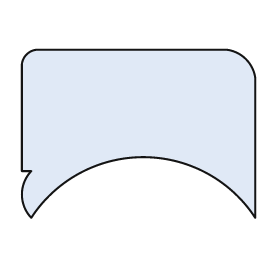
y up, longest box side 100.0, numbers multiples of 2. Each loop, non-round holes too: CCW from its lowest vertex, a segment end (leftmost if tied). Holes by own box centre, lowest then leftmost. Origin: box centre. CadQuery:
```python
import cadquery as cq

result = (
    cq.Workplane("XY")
    .moveTo(-46.0, -36.0)
    .threePointArc((2.0, -10.0), (50.0, -36.0))
    .lineTo(50.0, 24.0)
    .threePointArc((46.0, 32.0), (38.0, 36.0))
    .lineTo(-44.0, 36.0)
    .threePointArc((-48.0, 34.0), (-50.0, 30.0))
    .lineTo(-50.0, -16.0)
    .lineTo(-46.0, -16.0)
    .threePointArc((-50.0, -26.0), (-46.0, -36.0))
    .close()
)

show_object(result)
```